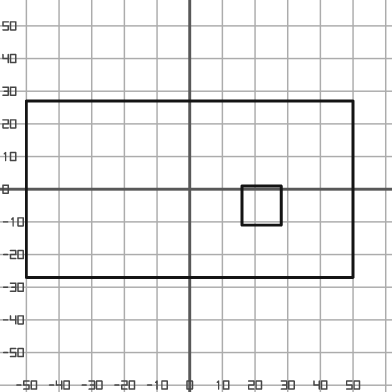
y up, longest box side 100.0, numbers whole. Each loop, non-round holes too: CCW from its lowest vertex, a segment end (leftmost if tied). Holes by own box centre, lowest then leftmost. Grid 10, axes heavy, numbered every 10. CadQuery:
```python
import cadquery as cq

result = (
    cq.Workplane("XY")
    .moveTo(-50.0, -27.0)
    .lineTo(50.0, -27.0)
    .lineTo(50.0, 27.0)
    .lineTo(-50.0, 27.0)
    .close()
    .moveTo(16.0, -11.0)
    .lineTo(28.0, -11.0)
    .lineTo(28.0, 1.0)
    .lineTo(16.0, 1.0)
    .close()
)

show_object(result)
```